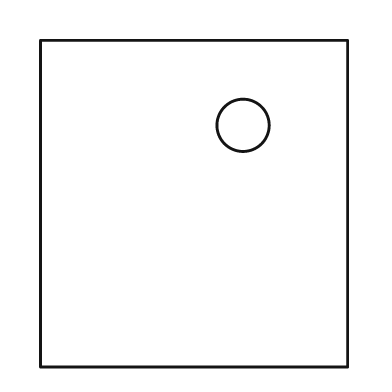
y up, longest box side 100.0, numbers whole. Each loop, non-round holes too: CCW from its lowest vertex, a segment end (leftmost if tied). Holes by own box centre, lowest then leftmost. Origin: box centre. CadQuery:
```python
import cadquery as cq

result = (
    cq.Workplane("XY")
    .moveTo(-47.0, -50.0)
    .lineTo(47.0, -50.0)
    .lineTo(47.0, 50.0)
    .lineTo(-47.0, 50.0)
    .close()
    .moveTo(15.0, 24.0)
    .circle(8.0)
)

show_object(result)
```